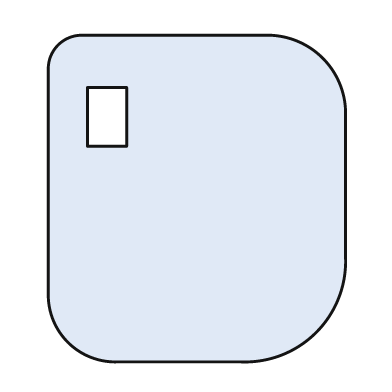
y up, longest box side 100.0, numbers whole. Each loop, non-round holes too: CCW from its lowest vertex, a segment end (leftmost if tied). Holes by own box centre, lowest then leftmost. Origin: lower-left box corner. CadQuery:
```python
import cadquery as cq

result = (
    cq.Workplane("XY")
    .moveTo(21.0, 0.0)
    .lineTo(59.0, 0.0)
    .threePointArc((82.0, 9.0), (91.0, 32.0))
    .lineTo(91.0, 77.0)
    .threePointArc((84.0, 93.0), (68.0, 100.0))
    .lineTo(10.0, 100.0)
    .threePointArc((3.0, 97.0), (0.0, 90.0))
    .lineTo(0.0, 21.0)
    .threePointArc((6.0, 6.0), (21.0, 0.0))
    .close()
    .moveTo(12.0, 66.0)
    .lineTo(24.0, 66.0)
    .lineTo(24.0, 84.0)
    .lineTo(12.0, 84.0)
    .close()
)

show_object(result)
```